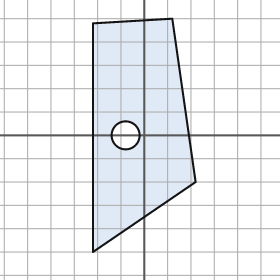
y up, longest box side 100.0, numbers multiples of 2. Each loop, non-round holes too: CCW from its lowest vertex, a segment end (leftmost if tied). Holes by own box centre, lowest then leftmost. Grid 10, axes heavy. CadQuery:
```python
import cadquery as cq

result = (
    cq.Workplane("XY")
    .moveTo(-22.0, -50.0)
    .lineTo(22.0, -20.0)
    .lineTo(12.0, 50.0)
    .lineTo(-22.0, 48.0)
    .close()
    .moveTo(-8.0, 0.0)
    .circle(6.0)
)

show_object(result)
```